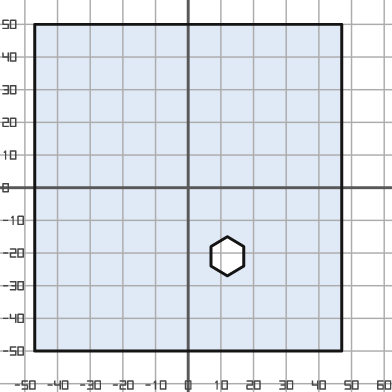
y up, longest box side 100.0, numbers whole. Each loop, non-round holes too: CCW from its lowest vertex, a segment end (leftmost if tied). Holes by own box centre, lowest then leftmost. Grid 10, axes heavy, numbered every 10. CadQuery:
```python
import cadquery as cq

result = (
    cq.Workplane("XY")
    .moveTo(-47.0, -50.0)
    .lineTo(47.0, -50.0)
    .lineTo(47.0, 50.0)
    .lineTo(-47.0, 50.0)
    .close()
    .moveTo(12.0, -27.0)
    .lineTo(17.0, -24.0)
    .lineTo(17.0, -18.0)
    .lineTo(12.0, -15.0)
    .lineTo(7.0, -18.0)
    .lineTo(7.0, -24.0)
    .close()
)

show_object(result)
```